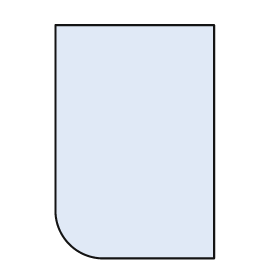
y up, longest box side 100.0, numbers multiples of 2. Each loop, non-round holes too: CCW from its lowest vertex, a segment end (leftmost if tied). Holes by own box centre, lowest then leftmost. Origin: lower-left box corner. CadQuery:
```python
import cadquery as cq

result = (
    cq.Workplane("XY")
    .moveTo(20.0, 0.0)
    .lineTo(68.0, 0.0)
    .lineTo(68.0, 100.0)
    .lineTo(0.0, 100.0)
    .lineTo(0.0, 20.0)
    .threePointArc((6.0, 6.0), (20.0, 0.0))
    .close()
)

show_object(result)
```